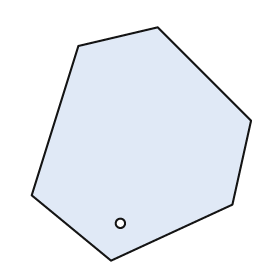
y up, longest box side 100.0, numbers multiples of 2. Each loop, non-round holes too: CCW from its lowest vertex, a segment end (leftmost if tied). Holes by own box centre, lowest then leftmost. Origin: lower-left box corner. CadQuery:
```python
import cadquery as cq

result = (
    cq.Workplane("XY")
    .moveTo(34.0, 0.0)
    .lineTo(86.0, 24.0)
    .lineTo(94.0, 60.0)
    .lineTo(54.0, 100.0)
    .lineTo(20.0, 92.0)
    .lineTo(0.0, 28.0)
    .close()
    .moveTo(38.0, 16.0)
    .circle(2.0)
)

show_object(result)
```